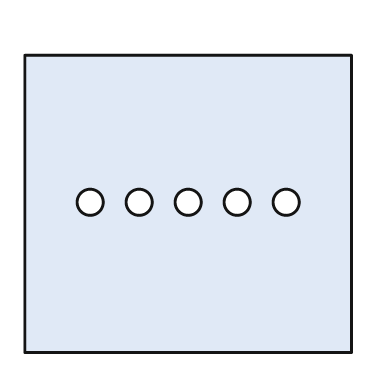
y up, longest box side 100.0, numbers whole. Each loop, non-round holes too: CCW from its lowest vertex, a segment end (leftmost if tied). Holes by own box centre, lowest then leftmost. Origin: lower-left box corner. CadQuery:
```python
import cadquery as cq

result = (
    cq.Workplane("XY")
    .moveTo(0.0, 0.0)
    .lineTo(100.0, 0.0)
    .lineTo(100.0, 91.0)
    .lineTo(0.0, 91.0)
    .close()
    .moveTo(20.0, 46.0)
    .circle(4.0)
    .moveTo(35.0, 46.0)
    .circle(4.0)
    .moveTo(50.0, 46.0)
    .circle(4.0)
    .moveTo(65.0, 46.0)
    .circle(4.0)
    .moveTo(80.0, 46.0)
    .circle(4.0)
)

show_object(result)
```